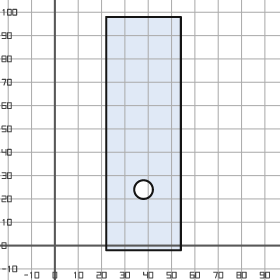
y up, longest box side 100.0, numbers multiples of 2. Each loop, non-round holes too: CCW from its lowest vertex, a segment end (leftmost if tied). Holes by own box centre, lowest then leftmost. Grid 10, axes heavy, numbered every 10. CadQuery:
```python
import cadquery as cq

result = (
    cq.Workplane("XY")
    .moveTo(22.0, -2.0)
    .lineTo(54.0, -2.0)
    .lineTo(54.0, 98.0)
    .lineTo(22.0, 98.0)
    .close()
    .moveTo(38.0, 24.0)
    .circle(4.0)
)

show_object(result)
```